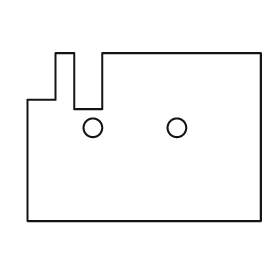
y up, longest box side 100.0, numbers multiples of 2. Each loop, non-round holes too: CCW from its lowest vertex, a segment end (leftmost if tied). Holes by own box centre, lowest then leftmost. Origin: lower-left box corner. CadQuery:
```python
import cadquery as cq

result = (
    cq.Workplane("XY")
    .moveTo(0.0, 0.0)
    .lineTo(100.0, 0.0)
    .lineTo(100.0, 72.0)
    .lineTo(32.0, 72.0)
    .lineTo(32.0, 48.0)
    .lineTo(20.0, 48.0)
    .lineTo(20.0, 72.0)
    .lineTo(12.0, 72.0)
    .lineTo(12.0, 52.0)
    .lineTo(0.0, 52.0)
    .close()
    .moveTo(28.0, 40.0)
    .circle(4.0)
    .moveTo(64.0, 40.0)
    .circle(4.0)
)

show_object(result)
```